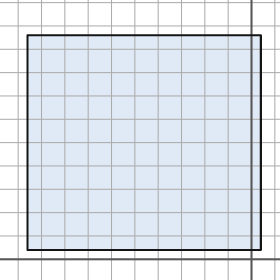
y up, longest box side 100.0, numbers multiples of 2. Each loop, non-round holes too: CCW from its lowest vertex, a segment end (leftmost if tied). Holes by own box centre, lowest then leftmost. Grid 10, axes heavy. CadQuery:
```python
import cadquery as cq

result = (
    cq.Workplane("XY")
    .moveTo(-96.0, 4.0)
    .lineTo(4.0, 4.0)
    .lineTo(4.0, 96.0)
    .lineTo(-96.0, 96.0)
    .close()
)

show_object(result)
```